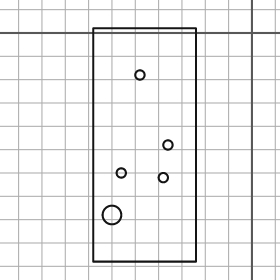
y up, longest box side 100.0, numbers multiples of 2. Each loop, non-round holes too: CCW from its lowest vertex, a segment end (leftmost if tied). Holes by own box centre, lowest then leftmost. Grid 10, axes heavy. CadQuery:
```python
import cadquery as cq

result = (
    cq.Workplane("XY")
    .moveTo(-68.0, -98.0)
    .lineTo(-24.0, -98.0)
    .lineTo(-24.0, 2.0)
    .lineTo(-68.0, 2.0)
    .close()
    .moveTo(-60.0, -78.0)
    .circle(4.0)
    .moveTo(-38.0, -62.0)
    .circle(2.0)
    .moveTo(-56.0, -60.0)
    .circle(2.0)
    .moveTo(-36.0, -48.0)
    .circle(2.0)
    .moveTo(-48.0, -18.0)
    .circle(2.0)
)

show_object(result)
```